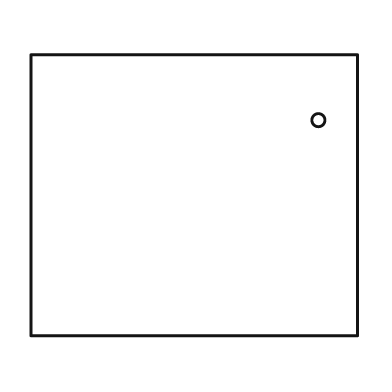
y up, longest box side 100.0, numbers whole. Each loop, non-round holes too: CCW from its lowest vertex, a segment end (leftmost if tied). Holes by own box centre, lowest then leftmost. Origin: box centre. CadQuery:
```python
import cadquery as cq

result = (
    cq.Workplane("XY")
    .moveTo(-50.0, -43.0)
    .lineTo(50.0, -43.0)
    .lineTo(50.0, 43.0)
    .lineTo(-50.0, 43.0)
    .close()
    .moveTo(38.0, 23.0)
    .circle(2.0)
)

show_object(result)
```